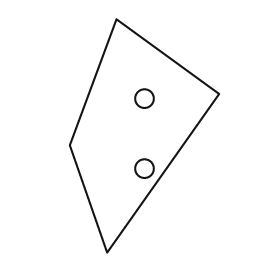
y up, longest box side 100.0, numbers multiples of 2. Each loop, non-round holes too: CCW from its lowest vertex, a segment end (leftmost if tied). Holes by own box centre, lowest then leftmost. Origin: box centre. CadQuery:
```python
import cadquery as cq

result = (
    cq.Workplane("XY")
    .moveTo(-16.0, -50.0)
    .lineTo(32.0, 18.0)
    .lineTo(-12.0, 50.0)
    .lineTo(-32.0, -4.0)
    .close()
    .moveTo(0.0, -14.0)
    .circle(4.0)
    .moveTo(0.0, 16.0)
    .circle(4.0)
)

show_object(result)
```